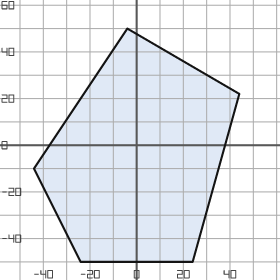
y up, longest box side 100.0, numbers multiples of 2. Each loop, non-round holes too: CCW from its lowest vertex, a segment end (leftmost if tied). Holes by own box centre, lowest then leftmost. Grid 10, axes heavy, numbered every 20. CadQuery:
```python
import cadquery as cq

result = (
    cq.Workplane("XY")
    .moveTo(-24.0, -50.0)
    .lineTo(24.0, -50.0)
    .lineTo(44.0, 22.0)
    .lineTo(-4.0, 50.0)
    .lineTo(-44.0, -10.0)
    .close()
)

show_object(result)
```